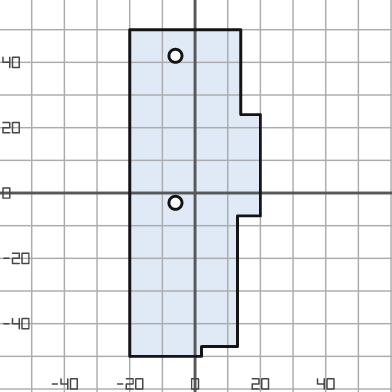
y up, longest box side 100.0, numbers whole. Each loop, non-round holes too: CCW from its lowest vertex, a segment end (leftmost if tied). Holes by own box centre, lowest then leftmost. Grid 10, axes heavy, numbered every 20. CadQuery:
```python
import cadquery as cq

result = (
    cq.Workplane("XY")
    .moveTo(-20.0, -50.0)
    .lineTo(2.0, -50.0)
    .lineTo(2.0, -47.0)
    .lineTo(13.0, -47.0)
    .lineTo(13.0, -7.0)
    .lineTo(20.0, -7.0)
    .lineTo(20.0, 24.0)
    .lineTo(14.0, 24.0)
    .lineTo(14.0, 50.0)
    .lineTo(-20.0, 50.0)
    .close()
    .moveTo(-6.0, -3.0)
    .circle(2.0)
    .moveTo(-6.0, 42.0)
    .circle(2.0)
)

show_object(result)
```